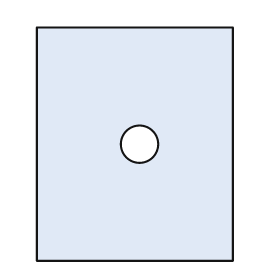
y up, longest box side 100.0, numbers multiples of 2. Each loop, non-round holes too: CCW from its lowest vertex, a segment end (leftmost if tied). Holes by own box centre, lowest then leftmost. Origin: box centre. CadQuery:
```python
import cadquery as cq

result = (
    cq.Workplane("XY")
    .moveTo(-42.0, -50.0)
    .lineTo(42.0, -50.0)
    .lineTo(42.0, 50.0)
    .lineTo(-42.0, 50.0)
    .close()
    .moveTo(2.0, 0.0)
    .circle(8.0)
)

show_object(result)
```